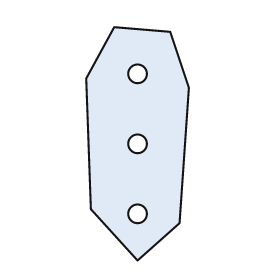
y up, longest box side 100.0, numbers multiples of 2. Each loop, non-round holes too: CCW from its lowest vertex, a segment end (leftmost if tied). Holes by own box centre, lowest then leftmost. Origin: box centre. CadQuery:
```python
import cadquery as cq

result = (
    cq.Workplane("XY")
    .moveTo(0.0, -50.0)
    .lineTo(18.0, -34.0)
    .lineTo(22.0, 24.0)
    .lineTo(14.0, 48.0)
    .lineTo(-10.0, 50.0)
    .lineTo(-22.0, 28.0)
    .lineTo(-20.0, -28.0)
    .close()
    .moveTo(0.0, -30.0)
    .circle(4.0)
    .moveTo(0.0, 0.0)
    .circle(4.0)
    .moveTo(0.0, 30.0)
    .circle(4.0)
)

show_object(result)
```